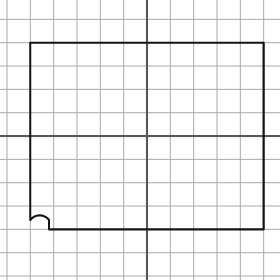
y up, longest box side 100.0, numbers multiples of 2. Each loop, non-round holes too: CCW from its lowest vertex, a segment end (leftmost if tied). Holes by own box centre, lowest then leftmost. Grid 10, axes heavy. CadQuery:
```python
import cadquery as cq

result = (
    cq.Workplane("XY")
    .moveTo(-42.0, -40.0)
    .lineTo(50.0, -40.0)
    .lineTo(50.0, 40.0)
    .lineTo(-50.0, 40.0)
    .lineTo(-50.0, -36.0)
    .threePointArc((-46.0, -34.0), (-42.0, -36.0))
    .close()
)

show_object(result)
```